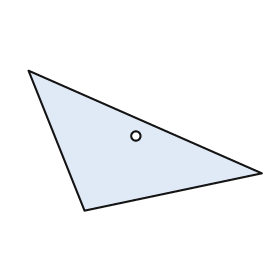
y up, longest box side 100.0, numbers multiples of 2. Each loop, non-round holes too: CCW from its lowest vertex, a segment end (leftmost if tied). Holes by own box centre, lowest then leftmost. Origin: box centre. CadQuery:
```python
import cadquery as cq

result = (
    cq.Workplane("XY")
    .moveTo(-26.0, -30.0)
    .lineTo(50.0, -14.0)
    .lineTo(-50.0, 30.0)
    .close()
    .moveTo(-4.0, 2.0)
    .circle(2.0)
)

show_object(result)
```